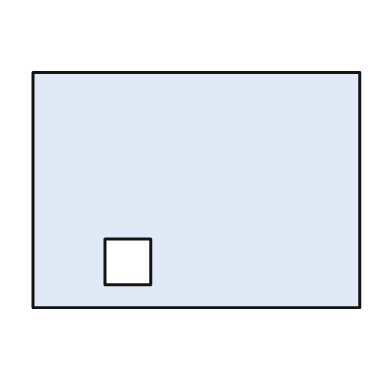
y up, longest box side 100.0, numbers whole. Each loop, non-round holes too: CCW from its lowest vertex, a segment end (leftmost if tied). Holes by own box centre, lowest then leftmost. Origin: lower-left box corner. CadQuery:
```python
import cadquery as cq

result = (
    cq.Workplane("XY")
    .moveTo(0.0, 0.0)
    .lineTo(100.0, 0.0)
    .lineTo(100.0, 72.0)
    .lineTo(0.0, 72.0)
    .close()
    .moveTo(22.0, 7.0)
    .lineTo(36.0, 7.0)
    .lineTo(36.0, 21.0)
    .lineTo(22.0, 21.0)
    .close()
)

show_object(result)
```